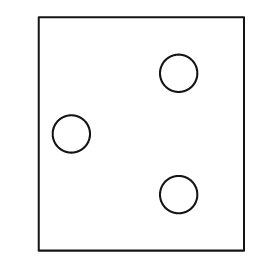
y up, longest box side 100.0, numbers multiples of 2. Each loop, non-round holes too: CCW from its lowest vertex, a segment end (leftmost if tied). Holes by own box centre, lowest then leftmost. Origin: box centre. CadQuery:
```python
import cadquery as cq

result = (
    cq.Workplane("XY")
    .moveTo(-44.0, -50.0)
    .lineTo(44.0, -50.0)
    .lineTo(44.0, 50.0)
    .lineTo(-44.0, 50.0)
    .close()
    .moveTo(16.0, -26.0)
    .circle(8.0)
    .moveTo(-30.0, 0.0)
    .circle(8.0)
    .moveTo(16.0, 26.0)
    .circle(8.0)
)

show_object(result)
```